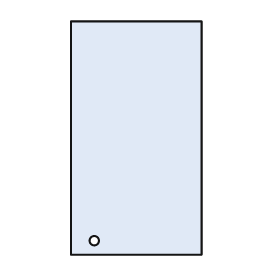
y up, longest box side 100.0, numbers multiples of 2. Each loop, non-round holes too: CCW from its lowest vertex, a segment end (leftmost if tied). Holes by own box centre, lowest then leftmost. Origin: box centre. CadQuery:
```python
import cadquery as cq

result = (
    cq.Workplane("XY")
    .moveTo(-28.0, -50.0)
    .lineTo(28.0, -50.0)
    .lineTo(28.0, 50.0)
    .lineTo(-28.0, 50.0)
    .close()
    .moveTo(-18.0, -44.0)
    .circle(2.0)
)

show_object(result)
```